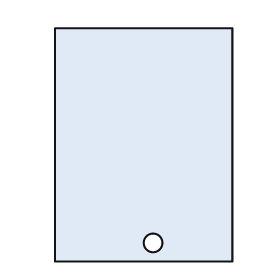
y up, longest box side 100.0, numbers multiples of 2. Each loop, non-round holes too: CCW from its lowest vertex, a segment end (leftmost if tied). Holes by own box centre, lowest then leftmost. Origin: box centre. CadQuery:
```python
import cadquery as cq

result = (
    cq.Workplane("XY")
    .moveTo(-38.0, -50.0)
    .lineTo(38.0, -50.0)
    .lineTo(38.0, 50.0)
    .lineTo(-38.0, 50.0)
    .close()
    .moveTo(4.0, -42.0)
    .circle(4.0)
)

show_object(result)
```